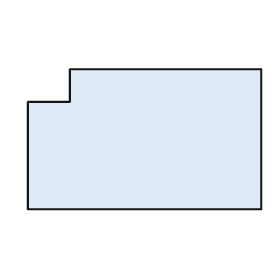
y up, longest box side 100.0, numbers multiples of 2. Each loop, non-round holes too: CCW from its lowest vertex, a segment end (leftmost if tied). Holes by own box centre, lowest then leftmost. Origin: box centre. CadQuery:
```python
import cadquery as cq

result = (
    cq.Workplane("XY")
    .moveTo(-50.0, -30.0)
    .lineTo(50.0, -30.0)
    .lineTo(50.0, 30.0)
    .lineTo(-32.0, 30.0)
    .lineTo(-32.0, 16.0)
    .lineTo(-50.0, 16.0)
    .close()
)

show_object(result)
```